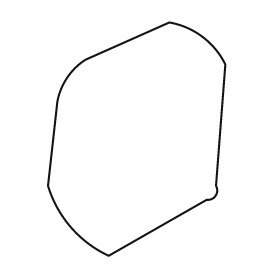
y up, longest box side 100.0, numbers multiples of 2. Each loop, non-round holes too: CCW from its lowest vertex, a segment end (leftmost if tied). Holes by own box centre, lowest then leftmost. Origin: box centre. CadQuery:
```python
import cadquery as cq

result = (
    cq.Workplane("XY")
    .moveTo(-12.0, -50.0)
    .lineTo(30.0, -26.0)
    .threePointArc((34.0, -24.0), (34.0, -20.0))
    .lineTo(38.0, 32.0)
    .threePointArc((28.0, 44.0), (14.0, 50.0))
    .lineTo(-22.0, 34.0)
    .threePointArc((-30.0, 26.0), (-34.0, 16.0))
    .lineTo(-38.0, -20.0)
    .threePointArc((-28.0, -38.0), (-12.0, -50.0))
    .close()
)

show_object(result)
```